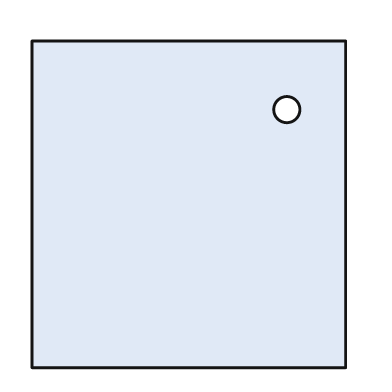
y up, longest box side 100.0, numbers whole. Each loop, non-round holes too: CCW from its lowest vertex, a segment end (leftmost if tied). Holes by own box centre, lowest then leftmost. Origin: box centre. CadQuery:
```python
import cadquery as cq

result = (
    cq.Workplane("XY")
    .moveTo(-48.0, -50.0)
    .lineTo(48.0, -50.0)
    .lineTo(48.0, 50.0)
    .lineTo(-48.0, 50.0)
    .close()
    .moveTo(30.0, 29.0)
    .circle(4.0)
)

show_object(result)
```